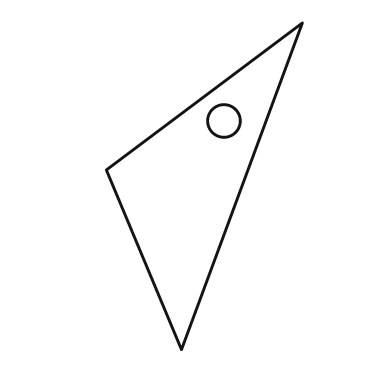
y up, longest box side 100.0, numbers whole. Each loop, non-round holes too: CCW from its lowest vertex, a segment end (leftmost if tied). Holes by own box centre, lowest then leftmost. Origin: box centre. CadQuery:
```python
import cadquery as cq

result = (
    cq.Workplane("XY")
    .moveTo(-7.0, -50.0)
    .lineTo(30.0, 50.0)
    .lineTo(-30.0, 5.0)
    .close()
    .moveTo(6.0, 20.0)
    .circle(5.0)
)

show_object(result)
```